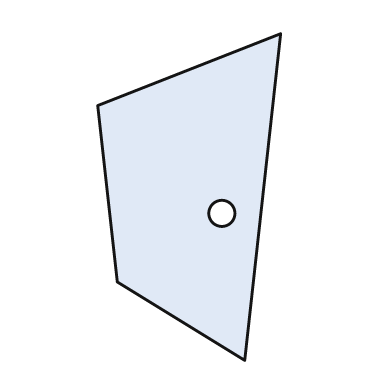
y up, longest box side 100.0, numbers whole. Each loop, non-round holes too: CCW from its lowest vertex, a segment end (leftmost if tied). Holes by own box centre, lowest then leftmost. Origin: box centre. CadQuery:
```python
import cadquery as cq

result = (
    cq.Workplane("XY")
    .moveTo(17.0, -50.0)
    .lineTo(28.0, 50.0)
    .lineTo(-28.0, 28.0)
    .lineTo(-22.0, -26.0)
    .close()
    .moveTo(10.0, -5.0)
    .circle(4.0)
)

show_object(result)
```